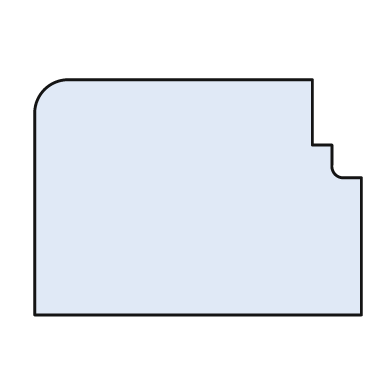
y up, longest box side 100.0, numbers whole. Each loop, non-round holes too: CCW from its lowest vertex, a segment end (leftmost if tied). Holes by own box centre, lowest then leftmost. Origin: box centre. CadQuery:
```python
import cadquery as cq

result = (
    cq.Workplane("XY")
    .moveTo(-50.0, -36.0)
    .lineTo(50.0, -36.0)
    .lineTo(50.0, 6.0)
    .lineTo(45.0, 6.0)
    .threePointArc((42.0, 7.0), (41.0, 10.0))
    .lineTo(41.0, 16.0)
    .lineTo(35.0, 16.0)
    .lineTo(35.0, 36.0)
    .lineTo(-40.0, 36.0)
    .threePointArc((-47.0, 33.0), (-50.0, 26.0))
    .close()
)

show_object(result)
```